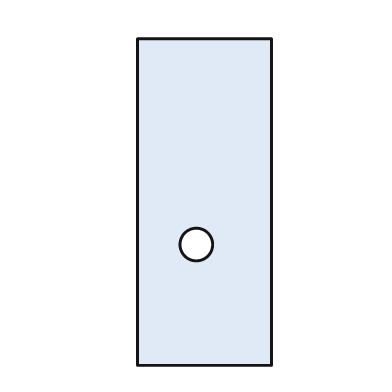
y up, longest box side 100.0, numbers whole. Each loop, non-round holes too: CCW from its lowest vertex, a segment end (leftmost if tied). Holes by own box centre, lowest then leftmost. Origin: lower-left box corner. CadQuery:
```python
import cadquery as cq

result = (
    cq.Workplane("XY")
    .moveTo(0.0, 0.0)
    .lineTo(41.0, 0.0)
    .lineTo(41.0, 100.0)
    .lineTo(0.0, 100.0)
    .close()
    .moveTo(18.0, 37.0)
    .circle(5.0)
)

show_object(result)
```